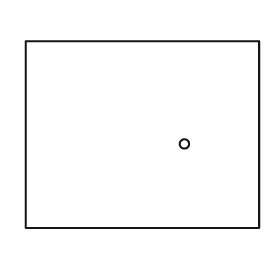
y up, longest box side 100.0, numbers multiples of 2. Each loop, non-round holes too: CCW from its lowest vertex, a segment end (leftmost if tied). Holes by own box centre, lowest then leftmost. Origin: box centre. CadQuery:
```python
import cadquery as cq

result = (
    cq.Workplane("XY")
    .moveTo(-50.0, -40.0)
    .lineTo(50.0, -40.0)
    .lineTo(50.0, 40.0)
    .lineTo(-50.0, 40.0)
    .close()
    .moveTo(18.0, -4.0)
    .circle(2.0)
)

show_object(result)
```